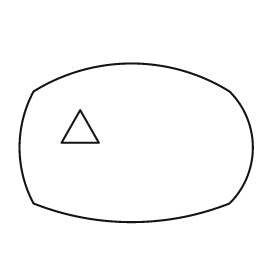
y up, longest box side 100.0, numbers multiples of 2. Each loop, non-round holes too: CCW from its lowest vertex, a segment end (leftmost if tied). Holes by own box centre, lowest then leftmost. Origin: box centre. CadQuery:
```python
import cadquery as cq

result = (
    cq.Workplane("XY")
    .moveTo(-44.0, -26.0)
    .threePointArc((-2.0, -34.0), (40.0, -26.0))
    .threePointArc((50.0, -2.0), (40.0, 22.0))
    .threePointArc((-2.0, 34.0), (-44.0, 22.0))
    .threePointArc((-50.0, -2.0), (-44.0, -26.0))
    .close()
    .moveTo(-32.0, 0.0)
    .lineTo(-16.0, 0.0)
    .lineTo(-24.0, 14.0)
    .close()
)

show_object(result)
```